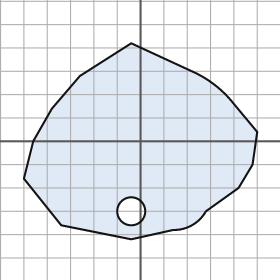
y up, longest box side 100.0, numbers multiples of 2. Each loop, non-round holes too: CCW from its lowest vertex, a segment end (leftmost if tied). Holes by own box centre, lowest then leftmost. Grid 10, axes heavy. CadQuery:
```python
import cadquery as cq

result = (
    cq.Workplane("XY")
    .moveTo(-4.0, -42.0)
    .lineTo(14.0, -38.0)
    .threePointArc((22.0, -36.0), (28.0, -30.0))
    .lineTo(42.0, -20.0)
    .lineTo(48.0, -10.0)
    .lineTo(50.0, 4.0)
    .lineTo(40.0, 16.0)
    .threePointArc((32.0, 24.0), (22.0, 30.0))
    .lineTo(-4.0, 42.0)
    .lineTo(-26.0, 28.0)
    .lineTo(-38.0, 14.0)
    .lineTo(-46.0, 0.0)
    .lineTo(-50.0, -16.0)
    .lineTo(-34.0, -36.0)
    .close()
    .moveTo(-4.0, -30.0)
    .circle(6.0)
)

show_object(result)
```